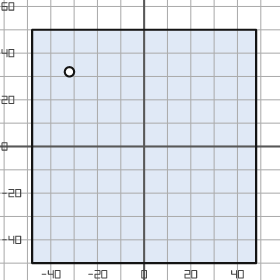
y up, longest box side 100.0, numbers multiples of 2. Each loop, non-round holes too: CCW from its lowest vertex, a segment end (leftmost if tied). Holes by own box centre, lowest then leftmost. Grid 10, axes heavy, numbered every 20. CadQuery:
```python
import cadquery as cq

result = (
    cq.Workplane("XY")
    .moveTo(-48.0, -50.0)
    .lineTo(48.0, -50.0)
    .lineTo(48.0, 50.0)
    .lineTo(-48.0, 50.0)
    .close()
    .moveTo(-32.0, 32.0)
    .circle(2.0)
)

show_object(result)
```